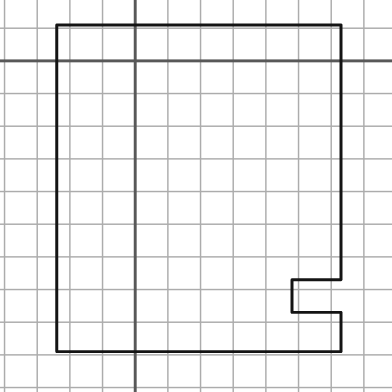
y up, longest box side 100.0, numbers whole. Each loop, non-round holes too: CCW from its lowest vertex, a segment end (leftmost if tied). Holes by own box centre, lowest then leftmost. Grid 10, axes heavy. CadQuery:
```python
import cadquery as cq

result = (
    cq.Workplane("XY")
    .moveTo(-24.0, -89.0)
    .lineTo(63.0, -89.0)
    .lineTo(63.0, -77.0)
    .lineTo(48.0, -77.0)
    .lineTo(48.0, -67.0)
    .lineTo(63.0, -67.0)
    .lineTo(63.0, 11.0)
    .lineTo(-24.0, 11.0)
    .close()
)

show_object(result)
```